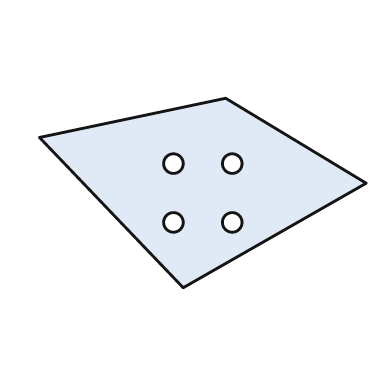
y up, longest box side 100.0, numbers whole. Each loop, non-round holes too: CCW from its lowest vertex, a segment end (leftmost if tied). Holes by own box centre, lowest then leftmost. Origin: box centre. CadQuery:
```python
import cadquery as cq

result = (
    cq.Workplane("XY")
    .moveTo(-6.0, -29.0)
    .lineTo(50.0, 3.0)
    .lineTo(7.0, 29.0)
    .lineTo(-50.0, 17.0)
    .close()
    .moveTo(-9.0, -9.0)
    .circle(3.0)
    .moveTo(9.0, -9.0)
    .circle(3.0)
    .moveTo(-9.0, 9.0)
    .circle(3.0)
    .moveTo(9.0, 9.0)
    .circle(3.0)
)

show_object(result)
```